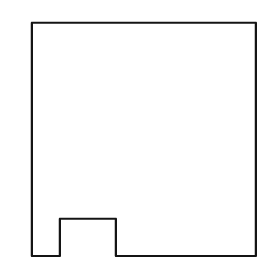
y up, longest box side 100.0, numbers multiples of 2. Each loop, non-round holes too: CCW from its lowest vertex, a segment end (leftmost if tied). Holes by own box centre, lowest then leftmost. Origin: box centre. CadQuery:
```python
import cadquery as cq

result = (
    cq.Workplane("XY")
    .moveTo(-48.0, -50.0)
    .lineTo(-36.0, -50.0)
    .lineTo(-36.0, -34.0)
    .lineTo(-12.0, -34.0)
    .lineTo(-12.0, -50.0)
    .lineTo(48.0, -50.0)
    .lineTo(48.0, 50.0)
    .lineTo(-48.0, 50.0)
    .close()
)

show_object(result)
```